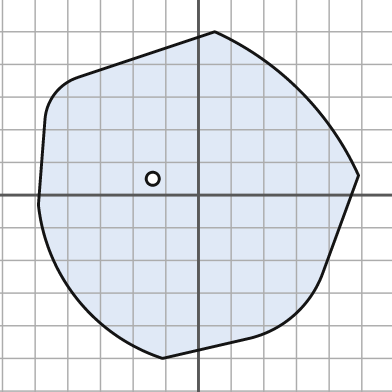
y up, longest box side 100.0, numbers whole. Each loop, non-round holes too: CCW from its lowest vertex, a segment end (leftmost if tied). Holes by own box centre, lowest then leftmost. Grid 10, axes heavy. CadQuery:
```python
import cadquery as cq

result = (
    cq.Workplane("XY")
    .moveTo(-11.0, -50.0)
    .lineTo(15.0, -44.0)
    .threePointArc((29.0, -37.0), (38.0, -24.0))
    .lineTo(49.0, 6.0)
    .threePointArc((31.0, 32.0), (5.0, 50.0))
    .lineTo(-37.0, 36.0)
    .threePointArc((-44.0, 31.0), (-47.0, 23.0))
    .lineTo(-49.0, -3.0)
    .threePointArc((-37.0, -32.0), (-11.0, -50.0))
    .close()
    .moveTo(-14.0, 5.0)
    .circle(2.0)
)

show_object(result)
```